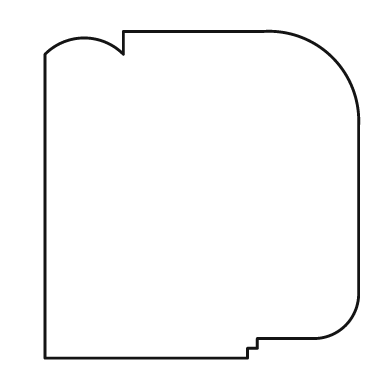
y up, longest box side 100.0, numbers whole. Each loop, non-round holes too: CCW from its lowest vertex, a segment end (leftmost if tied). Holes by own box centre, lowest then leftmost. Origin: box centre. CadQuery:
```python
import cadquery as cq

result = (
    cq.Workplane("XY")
    .moveTo(-48.0, -50.0)
    .lineTo(14.0, -50.0)
    .lineTo(14.0, -47.0)
    .lineTo(17.0, -47.0)
    .lineTo(17.0, -44.0)
    .lineTo(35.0, -44.0)
    .threePointArc((44.0, -40.0), (48.0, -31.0))
    .lineTo(48.0, 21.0)
    .threePointArc((40.0, 42.0), (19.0, 50.0))
    .lineTo(-24.0, 50.0)
    .lineTo(-24.0, 43.0)
    .threePointArc((-36.0, 48.0), (-48.0, 43.0))
    .close()
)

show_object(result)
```